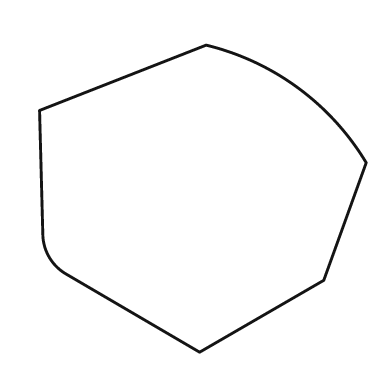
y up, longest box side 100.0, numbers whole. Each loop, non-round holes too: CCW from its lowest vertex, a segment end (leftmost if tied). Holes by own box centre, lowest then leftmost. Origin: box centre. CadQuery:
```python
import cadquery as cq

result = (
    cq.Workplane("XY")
    .moveTo(-1.0, -47.0)
    .lineTo(37.0, -25.0)
    .lineTo(50.0, 11.0)
    .threePointArc((29.0, 34.0), (1.0, 47.0))
    .lineTo(-50.0, 27.0)
    .lineTo(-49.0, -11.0)
    .threePointArc((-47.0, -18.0), (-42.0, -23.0))
    .close()
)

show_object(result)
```